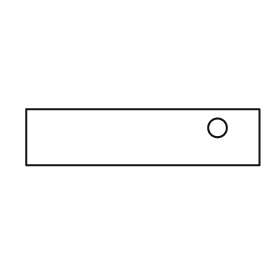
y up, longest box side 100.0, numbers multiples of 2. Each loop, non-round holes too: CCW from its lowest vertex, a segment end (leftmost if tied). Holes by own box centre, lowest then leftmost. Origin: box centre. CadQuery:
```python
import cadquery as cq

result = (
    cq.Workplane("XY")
    .moveTo(-50.0, -12.0)
    .lineTo(50.0, -12.0)
    .lineTo(50.0, 12.0)
    .lineTo(-50.0, 12.0)
    .close()
    .moveTo(32.0, 4.0)
    .circle(4.0)
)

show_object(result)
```